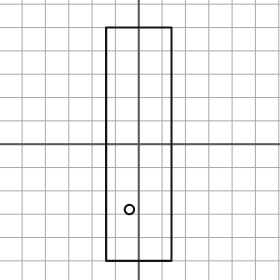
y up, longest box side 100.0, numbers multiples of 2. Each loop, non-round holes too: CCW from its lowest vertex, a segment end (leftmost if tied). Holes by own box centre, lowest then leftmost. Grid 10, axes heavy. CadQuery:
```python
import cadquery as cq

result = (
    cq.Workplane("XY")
    .moveTo(-14.0, -50.0)
    .lineTo(14.0, -50.0)
    .lineTo(14.0, 50.0)
    .lineTo(-14.0, 50.0)
    .close()
    .moveTo(-4.0, -28.0)
    .circle(2.0)
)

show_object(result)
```